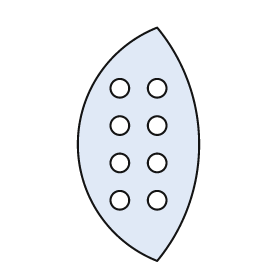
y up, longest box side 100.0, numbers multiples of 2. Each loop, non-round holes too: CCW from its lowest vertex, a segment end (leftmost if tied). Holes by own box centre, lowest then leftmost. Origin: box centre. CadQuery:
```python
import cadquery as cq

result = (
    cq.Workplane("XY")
    .moveTo(8.0, -50.0)
    .threePointArc((26.0, 0.0), (8.0, 50.0))
    .threePointArc((-26.0, 0.0), (8.0, -50.0))
    .close()
    .moveTo(-8.0, -24.0)
    .circle(4.0)
    .moveTo(8.0, -24.0)
    .circle(4.0)
    .moveTo(-8.0, -8.0)
    .circle(4.0)
    .moveTo(8.0, -8.0)
    .circle(4.0)
    .moveTo(-8.0, 8.0)
    .circle(4.0)
    .moveTo(8.0, 8.0)
    .circle(4.0)
    .moveTo(-8.0, 24.0)
    .circle(4.0)
    .moveTo(8.0, 24.0)
    .circle(4.0)
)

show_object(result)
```